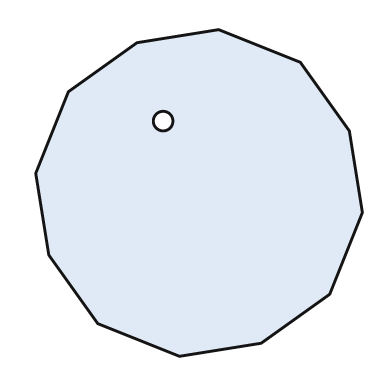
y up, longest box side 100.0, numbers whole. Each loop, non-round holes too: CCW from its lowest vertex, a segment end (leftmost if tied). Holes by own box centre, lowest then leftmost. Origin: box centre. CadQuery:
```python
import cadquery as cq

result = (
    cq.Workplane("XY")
    .moveTo(-6.0, -50.0)
    .lineTo(19.0, -46.0)
    .lineTo(40.0, -31.0)
    .lineTo(50.0, -6.0)
    .lineTo(46.0, 19.0)
    .lineTo(31.0, 40.0)
    .lineTo(6.0, 50.0)
    .lineTo(-19.0, 46.0)
    .lineTo(-40.0, 31.0)
    .lineTo(-50.0, 6.0)
    .lineTo(-46.0, -19.0)
    .lineTo(-31.0, -40.0)
    .close()
    .moveTo(-11.0, 22.0)
    .circle(3.0)
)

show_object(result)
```